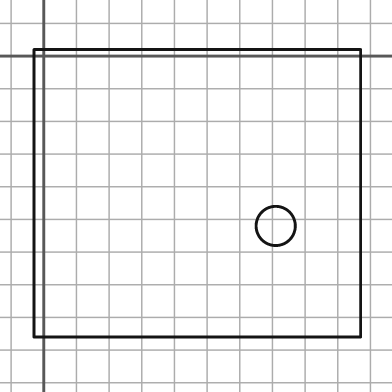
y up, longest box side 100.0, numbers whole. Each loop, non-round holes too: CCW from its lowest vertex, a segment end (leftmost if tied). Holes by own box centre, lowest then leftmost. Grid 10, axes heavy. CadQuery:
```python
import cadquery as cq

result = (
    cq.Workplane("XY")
    .moveTo(-3.0, -86.0)
    .lineTo(97.0, -86.0)
    .lineTo(97.0, 2.0)
    .lineTo(-3.0, 2.0)
    .close()
    .moveTo(71.0, -52.0)
    .circle(6.0)
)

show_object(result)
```